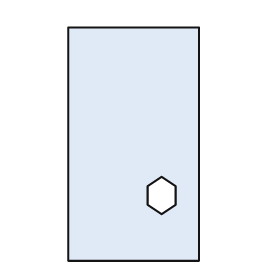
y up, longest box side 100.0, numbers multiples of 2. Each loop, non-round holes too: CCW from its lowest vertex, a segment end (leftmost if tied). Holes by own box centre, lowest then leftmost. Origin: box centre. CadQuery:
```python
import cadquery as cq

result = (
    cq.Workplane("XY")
    .moveTo(-28.0, -50.0)
    .lineTo(28.0, -50.0)
    .lineTo(28.0, 50.0)
    .lineTo(-28.0, 50.0)
    .close()
    .moveTo(12.0, -30.0)
    .lineTo(18.0, -26.0)
    .lineTo(18.0, -18.0)
    .lineTo(12.0, -14.0)
    .lineTo(6.0, -18.0)
    .lineTo(6.0, -26.0)
    .close()
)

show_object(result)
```